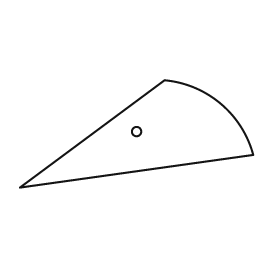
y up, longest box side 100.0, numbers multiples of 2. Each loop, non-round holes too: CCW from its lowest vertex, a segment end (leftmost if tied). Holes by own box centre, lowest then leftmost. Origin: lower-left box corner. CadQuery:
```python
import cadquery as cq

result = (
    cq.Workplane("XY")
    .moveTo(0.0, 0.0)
    .lineTo(100.0, 14.0)
    .threePointArc((86.0, 36.0), (62.0, 46.0))
    .close()
    .moveTo(50.0, 24.0)
    .circle(2.0)
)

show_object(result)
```